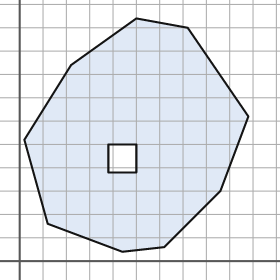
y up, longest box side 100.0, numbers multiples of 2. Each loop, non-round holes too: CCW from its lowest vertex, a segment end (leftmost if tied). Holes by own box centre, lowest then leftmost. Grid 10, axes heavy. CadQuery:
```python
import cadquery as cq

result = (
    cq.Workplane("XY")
    .moveTo(44.0, 4.0)
    .lineTo(62.0, 6.0)
    .lineTo(86.0, 30.0)
    .lineTo(98.0, 62.0)
    .lineTo(72.0, 100.0)
    .lineTo(50.0, 104.0)
    .lineTo(22.0, 84.0)
    .lineTo(2.0, 52.0)
    .lineTo(12.0, 16.0)
    .close()
    .moveTo(38.0, 38.0)
    .lineTo(50.0, 38.0)
    .lineTo(50.0, 50.0)
    .lineTo(38.0, 50.0)
    .close()
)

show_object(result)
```